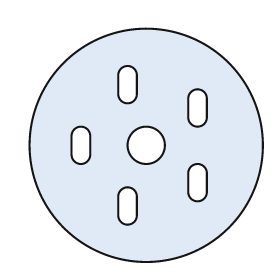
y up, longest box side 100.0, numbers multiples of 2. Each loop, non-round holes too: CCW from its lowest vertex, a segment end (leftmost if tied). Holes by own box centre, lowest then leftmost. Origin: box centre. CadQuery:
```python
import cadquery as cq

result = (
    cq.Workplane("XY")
    .moveTo(0.0, 0.0)
    .circle(50.0)
    .moveTo(-12.0, -30.0)
    .threePointArc((-8.0, -34.0), (-4.0, -30.0))
    .lineTo(-4.0, -22.0)
    .threePointArc((-8.0, -18.0), (-12.0, -22.0))
    .close()
    .moveTo(18.0, -20.0)
    .threePointArc((22.0, -24.0), (26.0, -20.0))
    .lineTo(26.0, -12.0)
    .threePointArc((22.0, -8.0), (18.0, -12.0))
    .close()
    .moveTo(-32.0, -4.0)
    .threePointArc((-28.0, -8.0), (-24.0, -4.0))
    .lineTo(-24.0, 4.0)
    .threePointArc((-28.0, 8.0), (-32.0, 4.0))
    .close()
    .moveTo(0.0, 0.0)
    .circle(8.0)
    .moveTo(18.0, 12.0)
    .threePointArc((22.0, 8.0), (26.0, 12.0))
    .lineTo(26.0, 20.0)
    .threePointArc((22.0, 24.0), (18.0, 20.0))
    .close()
    .moveTo(-12.0, 22.0)
    .threePointArc((-8.0, 18.0), (-4.0, 22.0))
    .lineTo(-4.0, 30.0)
    .threePointArc((-8.0, 34.0), (-12.0, 30.0))
    .close()
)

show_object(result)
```